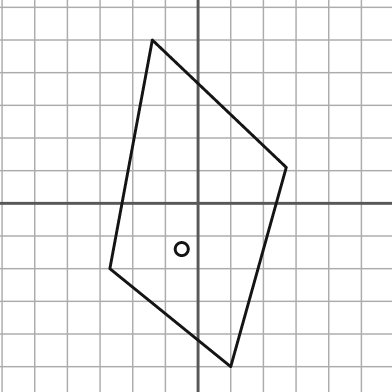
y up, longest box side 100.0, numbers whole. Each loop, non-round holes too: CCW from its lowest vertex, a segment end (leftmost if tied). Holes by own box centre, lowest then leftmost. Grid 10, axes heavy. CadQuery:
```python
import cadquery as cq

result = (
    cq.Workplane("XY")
    .moveTo(10.0, -50.0)
    .lineTo(27.0, 11.0)
    .lineTo(-14.0, 50.0)
    .lineTo(-27.0, -20.0)
    .close()
    .moveTo(-5.0, -14.0)
    .circle(2.0)
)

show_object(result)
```